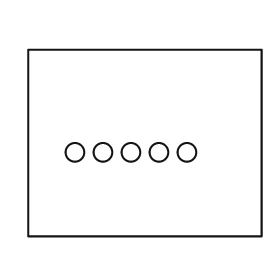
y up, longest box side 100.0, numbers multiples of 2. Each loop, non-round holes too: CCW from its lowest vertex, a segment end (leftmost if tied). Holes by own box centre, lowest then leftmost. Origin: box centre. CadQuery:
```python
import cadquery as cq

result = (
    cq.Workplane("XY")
    .moveTo(-50.0, -40.0)
    .lineTo(50.0, -40.0)
    .lineTo(50.0, 40.0)
    .lineTo(-50.0, 40.0)
    .close()
    .moveTo(-30.0, -4.0)
    .circle(4.0)
    .moveTo(-18.0, -4.0)
    .circle(4.0)
    .moveTo(-6.0, -4.0)
    .circle(4.0)
    .moveTo(6.0, -4.0)
    .circle(4.0)
    .moveTo(18.0, -4.0)
    .circle(4.0)
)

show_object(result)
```